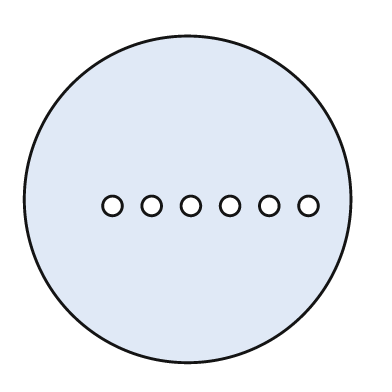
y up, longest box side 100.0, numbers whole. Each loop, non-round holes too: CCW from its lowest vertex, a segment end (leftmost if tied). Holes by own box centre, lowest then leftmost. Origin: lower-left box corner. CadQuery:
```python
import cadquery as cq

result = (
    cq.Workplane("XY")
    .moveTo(50.0, 50.0)
    .circle(50.0)
    .moveTo(27.0, 48.0)
    .circle(3.0)
    .moveTo(39.0, 48.0)
    .circle(3.0)
    .moveTo(51.0, 48.0)
    .circle(3.0)
    .moveTo(63.0, 48.0)
    .circle(3.0)
    .moveTo(75.0, 48.0)
    .circle(3.0)
    .moveTo(87.0, 48.0)
    .circle(3.0)
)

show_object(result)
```